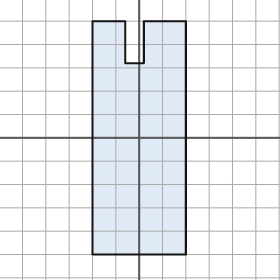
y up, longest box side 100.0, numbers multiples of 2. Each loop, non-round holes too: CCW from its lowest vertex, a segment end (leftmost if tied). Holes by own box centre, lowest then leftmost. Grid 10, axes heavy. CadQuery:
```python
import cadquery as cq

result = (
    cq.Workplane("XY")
    .moveTo(-20.0, -50.0)
    .lineTo(20.0, -50.0)
    .lineTo(20.0, 50.0)
    .lineTo(2.0, 50.0)
    .lineTo(2.0, 32.0)
    .lineTo(-6.0, 32.0)
    .lineTo(-6.0, 50.0)
    .lineTo(-20.0, 50.0)
    .close()
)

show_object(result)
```